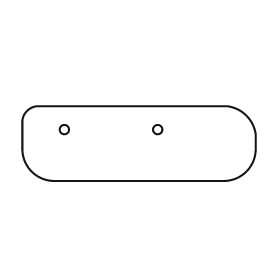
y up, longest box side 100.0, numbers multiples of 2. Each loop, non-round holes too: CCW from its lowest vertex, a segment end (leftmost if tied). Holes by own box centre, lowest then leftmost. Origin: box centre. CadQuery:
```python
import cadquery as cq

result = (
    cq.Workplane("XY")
    .moveTo(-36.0, -16.0)
    .lineTo(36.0, -16.0)
    .threePointArc((46.0, -12.0), (50.0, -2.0))
    .lineTo(50.0, 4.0)
    .threePointArc((46.0, 12.0), (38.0, 16.0))
    .lineTo(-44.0, 16.0)
    .threePointArc((-48.0, 14.0), (-50.0, 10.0))
    .lineTo(-50.0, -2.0)
    .threePointArc((-46.0, -12.0), (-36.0, -16.0))
    .close()
    .moveTo(-32.0, 6.0)
    .circle(2.0)
    .moveTo(8.0, 6.0)
    .circle(2.0)
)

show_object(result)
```